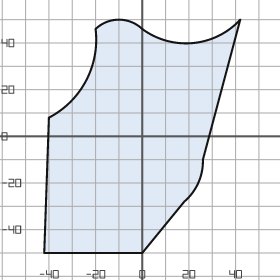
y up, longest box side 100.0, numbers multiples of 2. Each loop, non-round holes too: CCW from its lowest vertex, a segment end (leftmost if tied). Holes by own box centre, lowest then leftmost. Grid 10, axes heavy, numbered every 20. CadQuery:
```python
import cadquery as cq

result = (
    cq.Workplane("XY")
    .moveTo(-42.0, -50.0)
    .lineTo(0.0, -50.0)
    .lineTo(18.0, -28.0)
    .threePointArc((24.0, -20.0), (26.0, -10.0))
    .lineTo(42.0, 50.0)
    .threePointArc((22.0, 40.0), (0.0, 46.0))
    .threePointArc((-10.0, 50.0), (-20.0, 46.0))
    .threePointArc((-24.0, 24.0), (-40.0, 8.0))
    .close()
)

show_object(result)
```